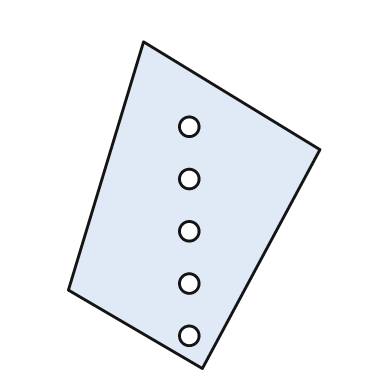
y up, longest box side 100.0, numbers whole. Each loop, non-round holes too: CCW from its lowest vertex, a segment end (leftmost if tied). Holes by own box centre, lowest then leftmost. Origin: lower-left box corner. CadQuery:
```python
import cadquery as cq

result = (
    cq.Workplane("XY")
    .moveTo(41.0, 0.0)
    .lineTo(77.0, 67.0)
    .lineTo(23.0, 100.0)
    .lineTo(0.0, 24.0)
    .close()
    .moveTo(37.0, 10.0)
    .circle(3.0)
    .moveTo(37.0, 26.0)
    .circle(3.0)
    .moveTo(37.0, 42.0)
    .circle(3.0)
    .moveTo(37.0, 58.0)
    .circle(3.0)
    .moveTo(37.0, 74.0)
    .circle(3.0)
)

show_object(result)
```